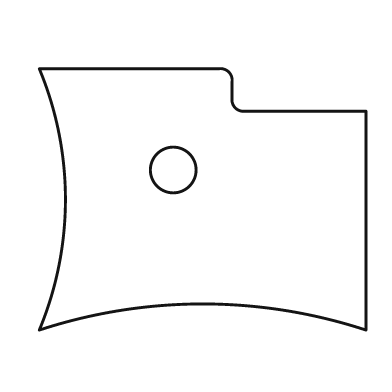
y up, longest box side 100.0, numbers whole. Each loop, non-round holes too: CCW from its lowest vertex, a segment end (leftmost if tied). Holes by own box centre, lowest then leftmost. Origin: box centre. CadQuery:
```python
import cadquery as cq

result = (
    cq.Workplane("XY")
    .moveTo(-50.0, -40.0)
    .threePointArc((0.0, -32.0), (50.0, -40.0))
    .lineTo(50.0, 27.0)
    .lineTo(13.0, 27.0)
    .threePointArc((10.0, 28.0), (9.0, 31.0))
    .lineTo(9.0, 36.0)
    .threePointArc((8.0, 39.0), (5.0, 40.0))
    .lineTo(-50.0, 40.0)
    .threePointArc((-42.0, 0.0), (-50.0, -40.0))
    .close()
    .moveTo(-9.0, 9.0)
    .circle(7.0)
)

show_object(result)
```